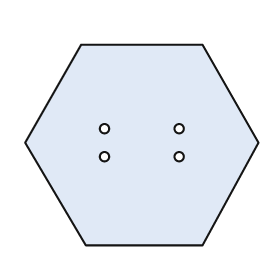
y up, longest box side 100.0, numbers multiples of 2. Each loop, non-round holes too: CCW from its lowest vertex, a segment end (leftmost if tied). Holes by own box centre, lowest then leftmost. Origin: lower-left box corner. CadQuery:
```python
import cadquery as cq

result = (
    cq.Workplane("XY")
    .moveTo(26.0, 0.0)
    .lineTo(76.0, 0.0)
    .lineTo(100.0, 44.0)
    .lineTo(76.0, 86.0)
    .lineTo(24.0, 86.0)
    .lineTo(0.0, 44.0)
    .close()
    .moveTo(34.0, 38.0)
    .circle(2.0)
    .moveTo(66.0, 38.0)
    .circle(2.0)
    .moveTo(34.0, 50.0)
    .circle(2.0)
    .moveTo(66.0, 50.0)
    .circle(2.0)
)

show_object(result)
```